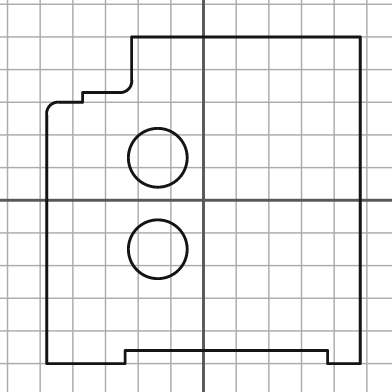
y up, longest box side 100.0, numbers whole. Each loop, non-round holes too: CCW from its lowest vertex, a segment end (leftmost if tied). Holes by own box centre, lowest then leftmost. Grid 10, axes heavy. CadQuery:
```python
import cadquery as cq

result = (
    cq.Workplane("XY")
    .moveTo(-48.0, -50.0)
    .lineTo(-24.0, -50.0)
    .lineTo(-24.0, -46.0)
    .lineTo(38.0, -46.0)
    .lineTo(38.0, -50.0)
    .lineTo(48.0, -50.0)
    .lineTo(48.0, 50.0)
    .lineTo(-22.0, 50.0)
    .lineTo(-22.0, 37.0)
    .threePointArc((-23.0, 34.0), (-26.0, 33.0))
    .lineTo(-37.0, 33.0)
    .lineTo(-37.0, 30.0)
    .lineTo(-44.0, 30.0)
    .threePointArc((-47.0, 29.0), (-48.0, 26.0))
    .close()
    .moveTo(-14.0, -15.0)
    .circle(9.0)
    .moveTo(-14.0, 13.0)
    .circle(9.0)
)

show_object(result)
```